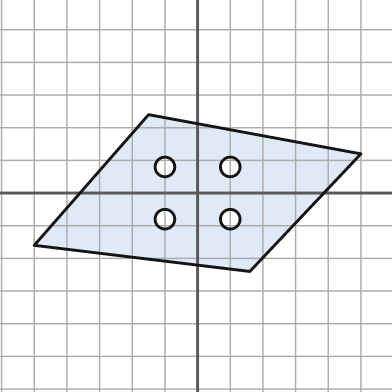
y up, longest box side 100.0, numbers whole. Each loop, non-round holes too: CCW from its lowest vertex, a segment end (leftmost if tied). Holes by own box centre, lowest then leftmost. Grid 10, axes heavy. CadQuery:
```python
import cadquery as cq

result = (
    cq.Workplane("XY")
    .moveTo(16.0, -24.0)
    .lineTo(50.0, 12.0)
    .lineTo(-15.0, 24.0)
    .lineTo(-50.0, -16.0)
    .close()
    .moveTo(-10.0, -8.0)
    .circle(3.0)
    .moveTo(10.0, -8.0)
    .circle(3.0)
    .moveTo(-10.0, 8.0)
    .circle(3.0)
    .moveTo(10.0, 8.0)
    .circle(3.0)
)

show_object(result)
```